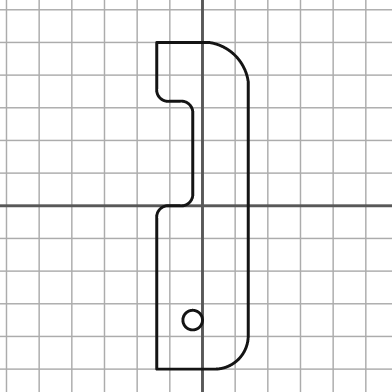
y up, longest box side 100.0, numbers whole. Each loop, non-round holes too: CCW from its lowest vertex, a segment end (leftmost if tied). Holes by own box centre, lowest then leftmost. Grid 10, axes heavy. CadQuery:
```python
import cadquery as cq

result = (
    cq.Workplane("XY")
    .moveTo(-14.0, -50.0)
    .lineTo(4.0, -50.0)
    .threePointArc((11.0, -47.0), (14.0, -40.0))
    .lineTo(14.0, 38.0)
    .threePointArc((10.0, 46.0), (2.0, 50.0))
    .lineTo(-14.0, 50.0)
    .lineTo(-14.0, 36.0)
    .threePointArc((-13.0, 33.0), (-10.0, 32.0))
    .lineTo(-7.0, 32.0)
    .threePointArc((-4.0, 31.0), (-3.0, 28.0))
    .lineTo(-3.0, 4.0)
    .threePointArc((-4.0, 1.0), (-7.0, 0.0))
    .lineTo(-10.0, 0.0)
    .threePointArc((-13.0, -1.0), (-14.0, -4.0))
    .close()
    .moveTo(-3.0, -35.0)
    .circle(3.0)
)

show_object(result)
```